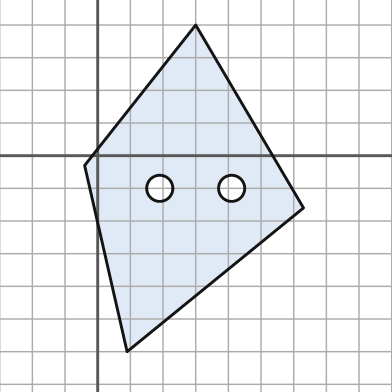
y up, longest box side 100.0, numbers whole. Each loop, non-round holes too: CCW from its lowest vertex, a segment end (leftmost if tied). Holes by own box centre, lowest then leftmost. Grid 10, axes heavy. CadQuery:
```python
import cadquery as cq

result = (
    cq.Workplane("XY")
    .moveTo(9.0, -60.0)
    .lineTo(63.0, -16.0)
    .lineTo(30.0, 40.0)
    .lineTo(-4.0, -3.0)
    .close()
    .moveTo(19.0, -10.0)
    .circle(4.0)
    .moveTo(41.0, -10.0)
    .circle(4.0)
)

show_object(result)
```